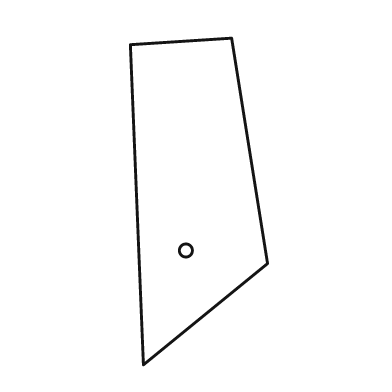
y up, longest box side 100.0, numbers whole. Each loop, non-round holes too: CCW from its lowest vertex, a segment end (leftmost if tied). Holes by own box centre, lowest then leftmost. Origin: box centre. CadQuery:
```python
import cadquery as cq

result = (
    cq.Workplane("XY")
    .moveTo(-17.0, -50.0)
    .lineTo(21.0, -19.0)
    .lineTo(10.0, 50.0)
    .lineTo(-21.0, 48.0)
    .close()
    .moveTo(-4.0, -15.0)
    .circle(2.0)
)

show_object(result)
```